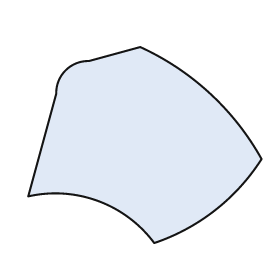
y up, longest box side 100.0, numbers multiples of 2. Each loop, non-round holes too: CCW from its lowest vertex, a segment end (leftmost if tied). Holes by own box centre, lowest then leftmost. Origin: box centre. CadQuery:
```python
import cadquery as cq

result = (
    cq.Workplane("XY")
    .moveTo(4.0, -42.0)
    .threePointArc((30.0, -28.0), (50.0, -6.0))
    .threePointArc((28.0, 22.0), (-2.0, 42.0))
    .lineTo(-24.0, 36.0)
    .threePointArc((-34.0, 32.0), (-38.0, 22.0))
    .lineTo(-50.0, -22.0)
    .threePointArc((-20.0, -24.0), (4.0, -42.0))
    .close()
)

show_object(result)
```